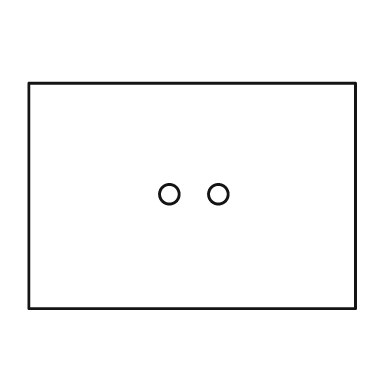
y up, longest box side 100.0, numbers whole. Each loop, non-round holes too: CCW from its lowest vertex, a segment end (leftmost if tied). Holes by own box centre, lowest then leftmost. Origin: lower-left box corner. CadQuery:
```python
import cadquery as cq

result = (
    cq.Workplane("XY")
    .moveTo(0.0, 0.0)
    .lineTo(100.0, 0.0)
    .lineTo(100.0, 69.0)
    .lineTo(0.0, 69.0)
    .close()
    .moveTo(43.0, 35.0)
    .circle(3.0)
    .moveTo(58.0, 35.0)
    .circle(3.0)
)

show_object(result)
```